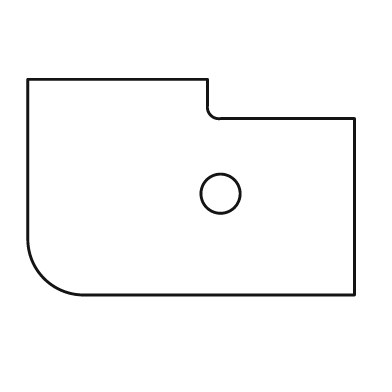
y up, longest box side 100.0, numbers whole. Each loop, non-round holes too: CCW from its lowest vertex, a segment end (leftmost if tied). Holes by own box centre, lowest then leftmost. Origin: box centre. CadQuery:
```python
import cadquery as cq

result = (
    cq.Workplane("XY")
    .moveTo(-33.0, -33.0)
    .lineTo(50.0, -33.0)
    .lineTo(50.0, 21.0)
    .lineTo(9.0, 21.0)
    .threePointArc((6.0, 22.0), (5.0, 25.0))
    .lineTo(5.0, 33.0)
    .lineTo(-50.0, 33.0)
    .lineTo(-50.0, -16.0)
    .threePointArc((-45.0, -28.0), (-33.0, -33.0))
    .close()
    .moveTo(9.0, -2.0)
    .circle(6.0)
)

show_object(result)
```